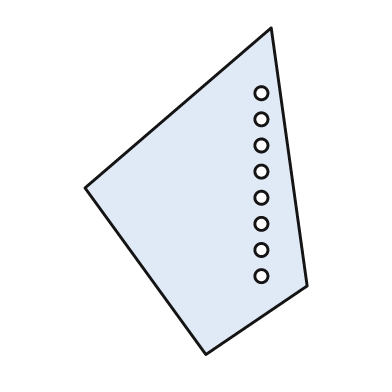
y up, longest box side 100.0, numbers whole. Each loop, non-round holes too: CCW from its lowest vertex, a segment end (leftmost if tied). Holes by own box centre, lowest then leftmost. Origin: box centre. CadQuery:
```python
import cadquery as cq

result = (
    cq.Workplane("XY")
    .moveTo(3.0, -50.0)
    .lineTo(34.0, -29.0)
    .lineTo(23.0, 50.0)
    .lineTo(-34.0, 1.0)
    .close()
    .moveTo(20.0, -26.0)
    .circle(2.0)
    .moveTo(20.0, -18.0)
    .circle(2.0)
    .moveTo(20.0, -10.0)
    .circle(2.0)
    .moveTo(20.0, -2.0)
    .circle(2.0)
    .moveTo(20.0, 6.0)
    .circle(2.0)
    .moveTo(20.0, 14.0)
    .circle(2.0)
    .moveTo(20.0, 22.0)
    .circle(2.0)
    .moveTo(20.0, 30.0)
    .circle(2.0)
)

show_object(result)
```